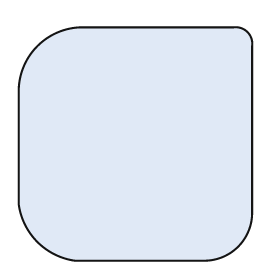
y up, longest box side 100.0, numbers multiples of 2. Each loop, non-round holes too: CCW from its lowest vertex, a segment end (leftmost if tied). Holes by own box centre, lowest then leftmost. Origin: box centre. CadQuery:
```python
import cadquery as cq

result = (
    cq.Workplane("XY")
    .moveTo(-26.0, -50.0)
    .lineTo(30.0, -50.0)
    .threePointArc((44.0, -44.0), (50.0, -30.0))
    .lineTo(50.0, 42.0)
    .threePointArc((48.0, 48.0), (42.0, 50.0))
    .lineTo(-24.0, 50.0)
    .threePointArc((-42.0, 42.0), (-50.0, 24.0))
    .lineTo(-50.0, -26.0)
    .threePointArc((-42.0, -42.0), (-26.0, -50.0))
    .close()
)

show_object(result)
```